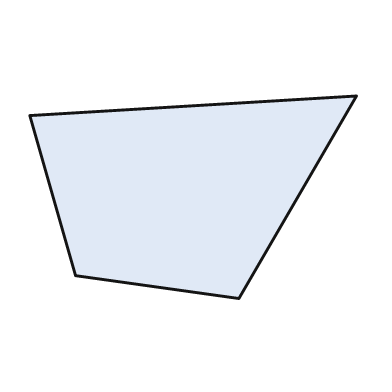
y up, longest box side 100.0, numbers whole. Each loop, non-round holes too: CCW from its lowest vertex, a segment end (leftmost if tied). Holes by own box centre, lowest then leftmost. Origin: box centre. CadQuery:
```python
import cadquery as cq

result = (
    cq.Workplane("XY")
    .moveTo(14.0, -31.0)
    .lineTo(50.0, 31.0)
    .lineTo(-50.0, 25.0)
    .lineTo(-36.0, -24.0)
    .close()
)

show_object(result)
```